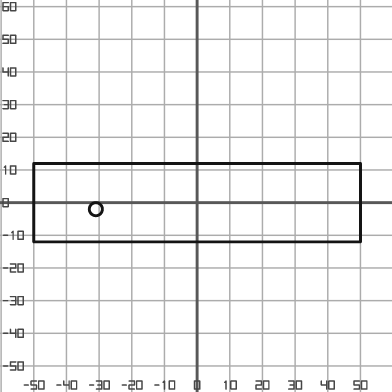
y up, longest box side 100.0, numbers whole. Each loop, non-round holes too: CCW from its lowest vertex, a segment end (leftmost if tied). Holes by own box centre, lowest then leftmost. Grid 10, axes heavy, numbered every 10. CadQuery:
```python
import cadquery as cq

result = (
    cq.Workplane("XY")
    .moveTo(-50.0, -12.0)
    .lineTo(50.0, -12.0)
    .lineTo(50.0, 12.0)
    .lineTo(-50.0, 12.0)
    .close()
    .moveTo(-31.0, -2.0)
    .circle(2.0)
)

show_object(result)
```